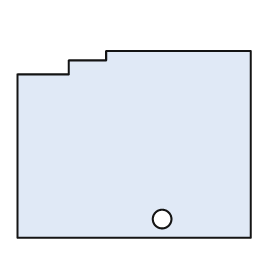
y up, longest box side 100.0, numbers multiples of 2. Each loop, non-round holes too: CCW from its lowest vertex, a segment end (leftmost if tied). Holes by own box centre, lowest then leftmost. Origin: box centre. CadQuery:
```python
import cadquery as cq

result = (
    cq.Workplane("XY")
    .moveTo(-50.0, -40.0)
    .lineTo(50.0, -40.0)
    .lineTo(50.0, 40.0)
    .lineTo(-12.0, 40.0)
    .lineTo(-12.0, 36.0)
    .lineTo(-28.0, 36.0)
    .lineTo(-28.0, 30.0)
    .lineTo(-50.0, 30.0)
    .close()
    .moveTo(12.0, -32.0)
    .circle(4.0)
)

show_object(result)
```